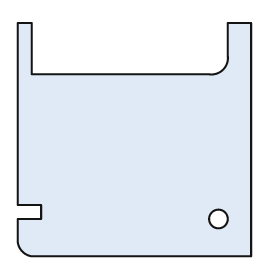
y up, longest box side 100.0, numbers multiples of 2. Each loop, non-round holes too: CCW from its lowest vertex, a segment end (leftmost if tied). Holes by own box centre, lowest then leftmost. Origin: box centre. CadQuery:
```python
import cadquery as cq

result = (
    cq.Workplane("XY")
    .moveTo(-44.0, -50.0)
    .lineTo(50.0, -50.0)
    .lineTo(50.0, 50.0)
    .lineTo(40.0, 50.0)
    .lineTo(40.0, 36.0)
    .threePointArc((38.0, 30.0), (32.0, 28.0))
    .lineTo(-44.0, 28.0)
    .lineTo(-44.0, 50.0)
    .lineTo(-50.0, 50.0)
    .lineTo(-50.0, -28.0)
    .lineTo(-40.0, -28.0)
    .lineTo(-40.0, -34.0)
    .lineTo(-50.0, -34.0)
    .lineTo(-50.0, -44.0)
    .threePointArc((-48.0, -48.0), (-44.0, -50.0))
    .close()
    .moveTo(36.0, -34.0)
    .circle(4.0)
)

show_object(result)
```